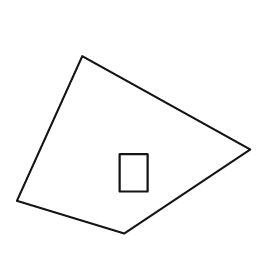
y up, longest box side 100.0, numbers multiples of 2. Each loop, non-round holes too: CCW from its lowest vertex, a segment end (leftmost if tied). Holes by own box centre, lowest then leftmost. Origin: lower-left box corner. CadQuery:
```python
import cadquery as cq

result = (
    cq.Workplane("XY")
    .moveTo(46.0, 0.0)
    .lineTo(100.0, 36.0)
    .lineTo(28.0, 76.0)
    .lineTo(0.0, 14.0)
    .close()
    .moveTo(44.0, 18.0)
    .lineTo(56.0, 18.0)
    .lineTo(56.0, 34.0)
    .lineTo(44.0, 34.0)
    .close()
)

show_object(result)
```